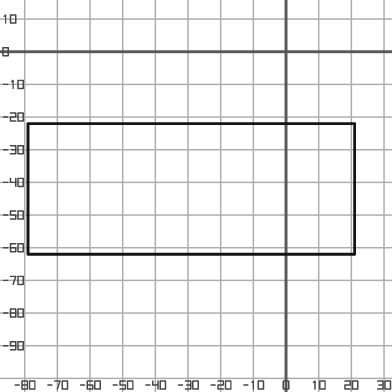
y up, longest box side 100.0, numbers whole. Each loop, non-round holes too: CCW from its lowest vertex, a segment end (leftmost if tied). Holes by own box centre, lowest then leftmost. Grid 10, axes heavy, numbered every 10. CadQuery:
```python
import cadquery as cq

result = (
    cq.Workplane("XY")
    .moveTo(-79.0, -62.0)
    .lineTo(21.0, -62.0)
    .lineTo(21.0, -22.0)
    .lineTo(-79.0, -22.0)
    .close()
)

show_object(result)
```